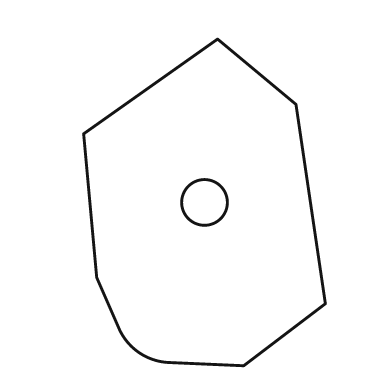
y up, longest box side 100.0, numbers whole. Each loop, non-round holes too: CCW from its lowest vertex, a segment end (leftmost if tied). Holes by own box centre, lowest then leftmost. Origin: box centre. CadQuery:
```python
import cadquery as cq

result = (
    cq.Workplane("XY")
    .moveTo(12.0, -50.0)
    .lineTo(37.0, -31.0)
    .lineTo(28.0, 30.0)
    .lineTo(4.0, 50.0)
    .lineTo(-37.0, 21.0)
    .lineTo(-33.0, -23.0)
    .lineTo(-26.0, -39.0)
    .threePointArc((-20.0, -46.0), (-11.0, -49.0))
    .close()
    .moveTo(0.0, 0.0)
    .circle(7.0)
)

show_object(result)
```